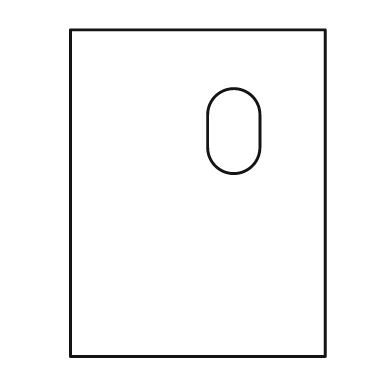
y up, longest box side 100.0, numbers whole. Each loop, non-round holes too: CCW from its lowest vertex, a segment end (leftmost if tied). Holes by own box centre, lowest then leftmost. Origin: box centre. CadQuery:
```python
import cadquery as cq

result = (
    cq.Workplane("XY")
    .moveTo(-39.0, -50.0)
    .lineTo(39.0, -50.0)
    .lineTo(39.0, 50.0)
    .lineTo(-39.0, 50.0)
    .close()
    .moveTo(3.0, 14.0)
    .threePointArc((11.0, 6.0), (19.0, 14.0))
    .lineTo(19.0, 24.0)
    .threePointArc((11.0, 32.0), (3.0, 24.0))
    .close()
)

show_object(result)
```